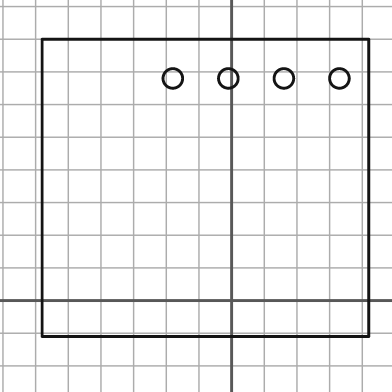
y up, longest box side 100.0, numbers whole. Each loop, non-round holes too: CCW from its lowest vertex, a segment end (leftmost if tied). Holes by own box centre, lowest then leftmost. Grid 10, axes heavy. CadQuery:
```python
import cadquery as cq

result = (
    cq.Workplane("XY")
    .moveTo(-58.0, -11.0)
    .lineTo(42.0, -11.0)
    .lineTo(42.0, 80.0)
    .lineTo(-58.0, 80.0)
    .close()
    .moveTo(-18.0, 68.0)
    .circle(3.0)
    .moveTo(-1.0, 68.0)
    .circle(3.0)
    .moveTo(16.0, 68.0)
    .circle(3.0)
    .moveTo(33.0, 68.0)
    .circle(3.0)
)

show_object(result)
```